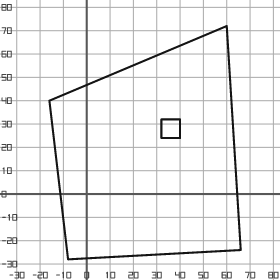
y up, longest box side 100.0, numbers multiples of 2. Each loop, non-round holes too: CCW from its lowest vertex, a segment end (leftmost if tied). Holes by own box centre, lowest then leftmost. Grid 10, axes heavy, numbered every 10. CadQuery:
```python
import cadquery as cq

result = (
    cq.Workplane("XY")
    .moveTo(-8.0, -28.0)
    .lineTo(66.0, -24.0)
    .lineTo(60.0, 72.0)
    .lineTo(-16.0, 40.0)
    .close()
    .moveTo(32.0, 24.0)
    .lineTo(40.0, 24.0)
    .lineTo(40.0, 32.0)
    .lineTo(32.0, 32.0)
    .close()
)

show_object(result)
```